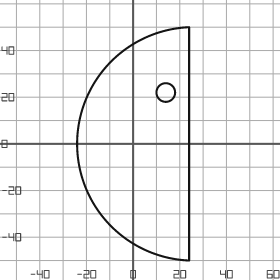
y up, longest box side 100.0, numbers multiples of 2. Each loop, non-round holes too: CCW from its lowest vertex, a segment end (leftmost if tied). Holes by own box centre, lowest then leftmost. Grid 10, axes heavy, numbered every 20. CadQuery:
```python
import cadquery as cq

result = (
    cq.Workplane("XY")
    .moveTo(24.0, -50.0)
    .lineTo(24.0, 50.0)
    .threePointArc((-24.0, 0.0), (24.0, -50.0))
    .close()
    .moveTo(14.0, 22.0)
    .circle(4.0)
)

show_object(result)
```